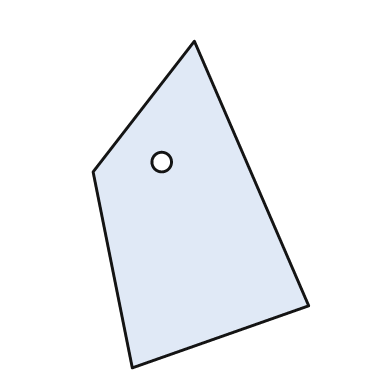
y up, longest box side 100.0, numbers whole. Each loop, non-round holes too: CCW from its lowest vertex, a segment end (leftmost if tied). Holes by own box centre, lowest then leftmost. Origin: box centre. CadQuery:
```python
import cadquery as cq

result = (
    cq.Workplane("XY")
    .moveTo(-21.0, -50.0)
    .lineTo(33.0, -31.0)
    .lineTo(-2.0, 50.0)
    .lineTo(-33.0, 10.0)
    .close()
    .moveTo(-12.0, 13.0)
    .circle(3.0)
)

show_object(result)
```